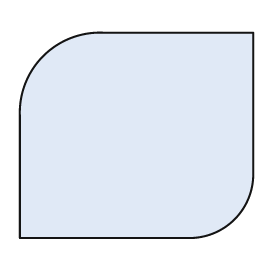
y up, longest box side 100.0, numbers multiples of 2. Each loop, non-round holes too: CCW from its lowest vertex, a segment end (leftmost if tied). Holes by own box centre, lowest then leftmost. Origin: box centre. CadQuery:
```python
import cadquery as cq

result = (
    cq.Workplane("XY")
    .moveTo(-50.0, -44.0)
    .lineTo(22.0, -44.0)
    .threePointArc((42.0, -36.0), (50.0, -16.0))
    .lineTo(50.0, 44.0)
    .lineTo(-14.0, 44.0)
    .threePointArc((-40.0, 34.0), (-50.0, 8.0))
    .close()
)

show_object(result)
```